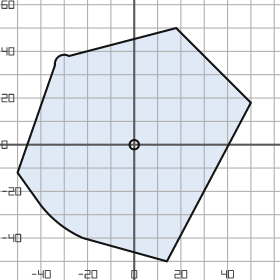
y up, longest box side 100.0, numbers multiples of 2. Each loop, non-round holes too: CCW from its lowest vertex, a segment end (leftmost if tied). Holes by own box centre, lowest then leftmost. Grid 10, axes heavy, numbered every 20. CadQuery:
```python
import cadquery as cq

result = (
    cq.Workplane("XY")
    .moveTo(14.0, -50.0)
    .lineTo(50.0, 18.0)
    .lineTo(18.0, 50.0)
    .lineTo(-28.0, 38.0)
    .threePointArc((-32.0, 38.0), (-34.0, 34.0))
    .lineTo(-50.0, -12.0)
    .lineTo(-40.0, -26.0)
    .threePointArc((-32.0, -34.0), (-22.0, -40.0))
    .close()
    .moveTo(0.0, 0.0)
    .circle(2.0)
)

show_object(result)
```